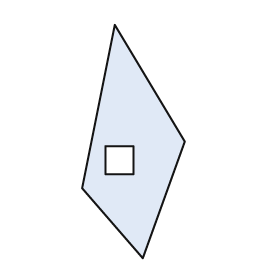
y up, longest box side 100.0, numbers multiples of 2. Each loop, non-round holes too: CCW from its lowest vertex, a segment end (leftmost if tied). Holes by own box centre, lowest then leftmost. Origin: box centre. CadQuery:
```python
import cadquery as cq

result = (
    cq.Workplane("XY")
    .moveTo(4.0, -50.0)
    .lineTo(22.0, 0.0)
    .lineTo(-8.0, 50.0)
    .lineTo(-22.0, -20.0)
    .close()
    .moveTo(-12.0, -14.0)
    .lineTo(0.0, -14.0)
    .lineTo(0.0, -2.0)
    .lineTo(-12.0, -2.0)
    .close()
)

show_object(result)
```